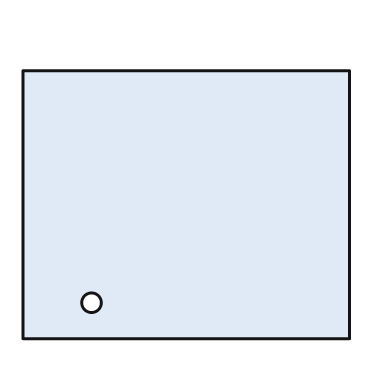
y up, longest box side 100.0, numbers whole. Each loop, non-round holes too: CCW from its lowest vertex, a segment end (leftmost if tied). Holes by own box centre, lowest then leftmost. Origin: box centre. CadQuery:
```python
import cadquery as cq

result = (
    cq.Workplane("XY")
    .moveTo(-50.0, -41.0)
    .lineTo(50.0, -41.0)
    .lineTo(50.0, 41.0)
    .lineTo(-50.0, 41.0)
    .close()
    .moveTo(-29.0, -30.0)
    .circle(3.0)
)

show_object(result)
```